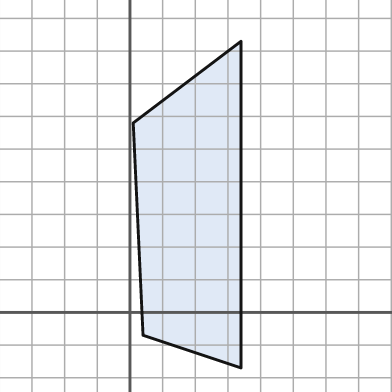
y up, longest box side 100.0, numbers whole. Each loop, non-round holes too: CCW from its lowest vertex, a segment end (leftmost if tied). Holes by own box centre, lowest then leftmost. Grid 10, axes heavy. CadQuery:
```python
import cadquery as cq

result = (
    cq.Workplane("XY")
    .moveTo(34.0, -17.0)
    .lineTo(34.0, 83.0)
    .lineTo(1.0, 58.0)
    .lineTo(4.0, -7.0)
    .close()
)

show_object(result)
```